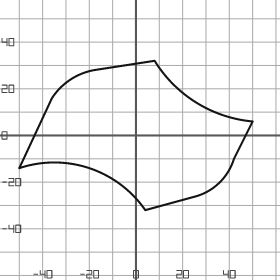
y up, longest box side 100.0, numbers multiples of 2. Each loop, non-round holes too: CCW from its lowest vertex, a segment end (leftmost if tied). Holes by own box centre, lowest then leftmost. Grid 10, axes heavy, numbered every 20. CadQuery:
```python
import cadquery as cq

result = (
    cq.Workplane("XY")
    .moveTo(4.0, -32.0)
    .lineTo(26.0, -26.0)
    .threePointArc((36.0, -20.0), (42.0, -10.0))
    .lineTo(50.0, 6.0)
    .threePointArc((26.0, 14.0), (8.0, 32.0))
    .lineTo(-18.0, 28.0)
    .threePointArc((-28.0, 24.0), (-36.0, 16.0))
    .lineTo(-50.0, -14.0)
    .threePointArc((-20.0, -14.0), (4.0, -32.0))
    .close()
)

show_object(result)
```